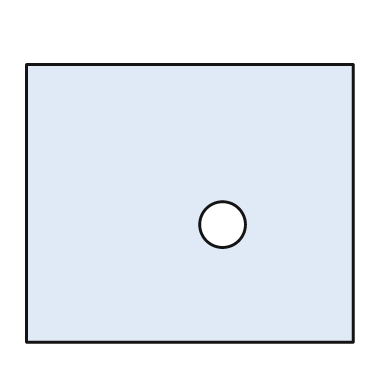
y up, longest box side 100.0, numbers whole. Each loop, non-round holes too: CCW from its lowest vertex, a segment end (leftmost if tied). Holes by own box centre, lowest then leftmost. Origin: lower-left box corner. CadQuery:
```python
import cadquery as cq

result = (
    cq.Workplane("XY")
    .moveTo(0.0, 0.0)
    .lineTo(100.0, 0.0)
    .lineTo(100.0, 85.0)
    .lineTo(0.0, 85.0)
    .close()
    .moveTo(60.0, 36.0)
    .circle(7.0)
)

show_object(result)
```